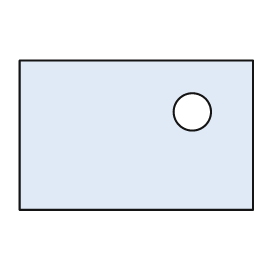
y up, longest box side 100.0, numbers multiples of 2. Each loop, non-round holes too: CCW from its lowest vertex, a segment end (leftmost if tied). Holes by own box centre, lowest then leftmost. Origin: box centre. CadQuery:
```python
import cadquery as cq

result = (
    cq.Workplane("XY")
    .moveTo(-50.0, -32.0)
    .lineTo(50.0, -32.0)
    .lineTo(50.0, 32.0)
    .lineTo(-50.0, 32.0)
    .close()
    .moveTo(24.0, 10.0)
    .circle(8.0)
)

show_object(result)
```